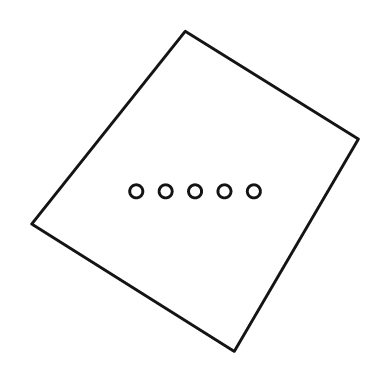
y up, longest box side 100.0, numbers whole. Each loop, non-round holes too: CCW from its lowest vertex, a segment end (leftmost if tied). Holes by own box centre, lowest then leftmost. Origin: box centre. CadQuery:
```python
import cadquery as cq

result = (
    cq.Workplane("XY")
    .moveTo(12.0, -49.0)
    .lineTo(50.0, 16.0)
    .lineTo(-3.0, 49.0)
    .lineTo(-50.0, -10.0)
    .close()
    .moveTo(-18.0, 0.0)
    .circle(2.0)
    .moveTo(-9.0, 0.0)
    .circle(2.0)
    .moveTo(0.0, 0.0)
    .circle(2.0)
    .moveTo(9.0, 0.0)
    .circle(2.0)
    .moveTo(18.0, 0.0)
    .circle(2.0)
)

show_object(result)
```